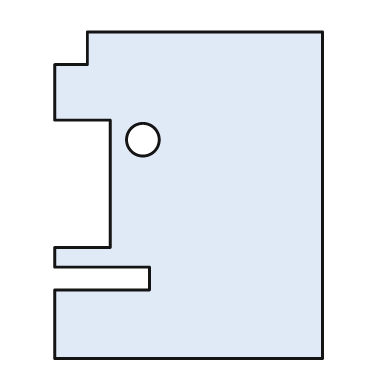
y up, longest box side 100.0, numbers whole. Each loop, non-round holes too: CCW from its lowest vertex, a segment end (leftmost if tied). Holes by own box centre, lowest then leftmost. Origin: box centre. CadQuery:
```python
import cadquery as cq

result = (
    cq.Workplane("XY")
    .moveTo(-41.0, -50.0)
    .lineTo(41.0, -50.0)
    .lineTo(41.0, 50.0)
    .lineTo(-31.0, 50.0)
    .lineTo(-31.0, 40.0)
    .lineTo(-41.0, 40.0)
    .lineTo(-41.0, 23.0)
    .lineTo(-24.0, 23.0)
    .lineTo(-24.0, -16.0)
    .lineTo(-41.0, -16.0)
    .lineTo(-41.0, -22.0)
    .lineTo(-12.0, -22.0)
    .lineTo(-12.0, -29.0)
    .lineTo(-41.0, -29.0)
    .close()
    .moveTo(-14.0, 17.0)
    .circle(5.0)
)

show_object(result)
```